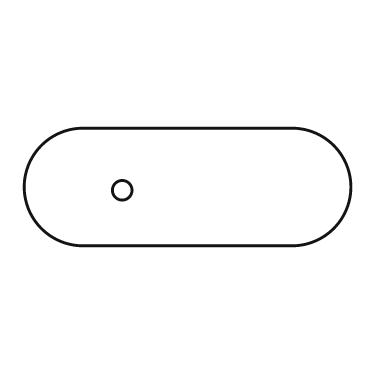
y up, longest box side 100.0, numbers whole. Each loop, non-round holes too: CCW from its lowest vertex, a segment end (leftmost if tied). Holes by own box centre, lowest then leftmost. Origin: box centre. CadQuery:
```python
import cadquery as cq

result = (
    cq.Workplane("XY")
    .moveTo(-32.0, -18.0)
    .lineTo(32.0, -18.0)
    .threePointArc((50.0, 0.0), (32.0, 18.0))
    .lineTo(-32.0, 18.0)
    .threePointArc((-50.0, 0.0), (-32.0, -18.0))
    .close()
    .moveTo(-20.0, -1.0)
    .circle(3.0)
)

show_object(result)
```